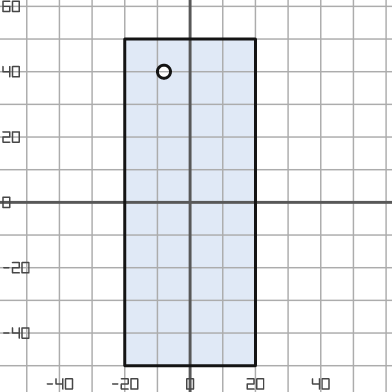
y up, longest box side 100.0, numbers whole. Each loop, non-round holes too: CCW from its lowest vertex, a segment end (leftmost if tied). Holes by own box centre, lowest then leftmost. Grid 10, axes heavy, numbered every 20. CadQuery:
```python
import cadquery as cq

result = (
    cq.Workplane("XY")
    .moveTo(-20.0, -50.0)
    .lineTo(20.0, -50.0)
    .lineTo(20.0, 50.0)
    .lineTo(-20.0, 50.0)
    .close()
    .moveTo(-8.0, 40.0)
    .circle(2.0)
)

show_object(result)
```